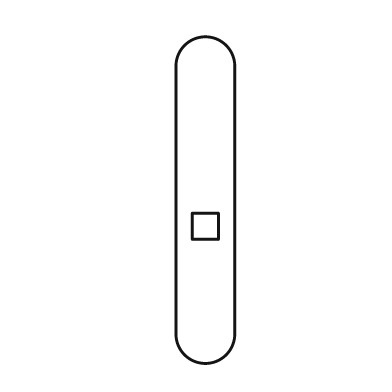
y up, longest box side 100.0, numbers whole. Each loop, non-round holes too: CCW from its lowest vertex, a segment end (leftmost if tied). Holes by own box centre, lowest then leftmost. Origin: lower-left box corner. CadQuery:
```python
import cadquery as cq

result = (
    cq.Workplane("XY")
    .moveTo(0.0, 9.0)
    .threePointArc((9.0, 0.0), (18.0, 9.0))
    .lineTo(18.0, 91.0)
    .threePointArc((9.0, 100.0), (0.0, 91.0))
    .close()
    .moveTo(5.0, 38.0)
    .lineTo(13.0, 38.0)
    .lineTo(13.0, 46.0)
    .lineTo(5.0, 46.0)
    .close()
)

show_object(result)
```